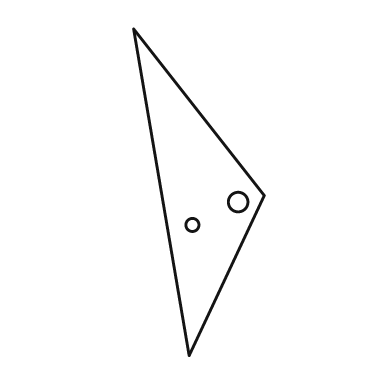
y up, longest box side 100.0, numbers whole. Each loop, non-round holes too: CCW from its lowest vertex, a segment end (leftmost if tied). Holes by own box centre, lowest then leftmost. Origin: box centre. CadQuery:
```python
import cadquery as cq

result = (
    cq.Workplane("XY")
    .moveTo(-3.0, -50.0)
    .lineTo(20.0, -1.0)
    .lineTo(-20.0, 50.0)
    .close()
    .moveTo(-2.0, -10.0)
    .circle(2.0)
    .moveTo(12.0, -3.0)
    .circle(3.0)
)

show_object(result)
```